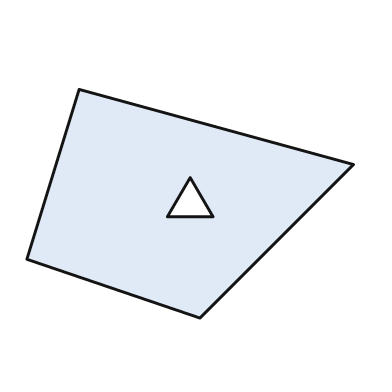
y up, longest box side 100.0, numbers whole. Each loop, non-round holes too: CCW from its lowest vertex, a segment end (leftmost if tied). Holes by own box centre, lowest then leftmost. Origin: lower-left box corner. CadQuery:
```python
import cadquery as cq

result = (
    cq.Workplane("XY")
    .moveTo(53.0, 0.0)
    .lineTo(100.0, 47.0)
    .lineTo(16.0, 70.0)
    .lineTo(0.0, 18.0)
    .close()
    .moveTo(43.0, 31.0)
    .lineTo(57.0, 31.0)
    .lineTo(50.0, 43.0)
    .close()
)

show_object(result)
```